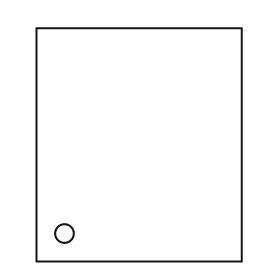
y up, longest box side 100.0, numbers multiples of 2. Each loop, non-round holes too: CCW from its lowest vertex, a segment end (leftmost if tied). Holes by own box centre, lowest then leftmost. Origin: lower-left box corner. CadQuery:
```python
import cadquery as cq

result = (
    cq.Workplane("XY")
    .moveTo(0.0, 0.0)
    .lineTo(88.0, 0.0)
    .lineTo(88.0, 100.0)
    .lineTo(0.0, 100.0)
    .close()
    .moveTo(12.0, 12.0)
    .circle(4.0)
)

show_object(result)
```